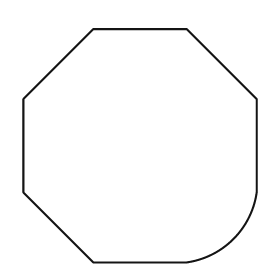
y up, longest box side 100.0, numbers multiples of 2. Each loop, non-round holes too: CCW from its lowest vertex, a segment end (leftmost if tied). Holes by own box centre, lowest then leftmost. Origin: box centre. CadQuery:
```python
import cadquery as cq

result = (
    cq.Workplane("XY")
    .moveTo(-20.0, -50.0)
    .lineTo(20.0, -50.0)
    .threePointArc((40.0, -40.0), (50.0, -20.0))
    .lineTo(50.0, 20.0)
    .lineTo(20.0, 50.0)
    .lineTo(-20.0, 50.0)
    .lineTo(-50.0, 20.0)
    .lineTo(-50.0, -20.0)
    .close()
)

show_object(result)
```